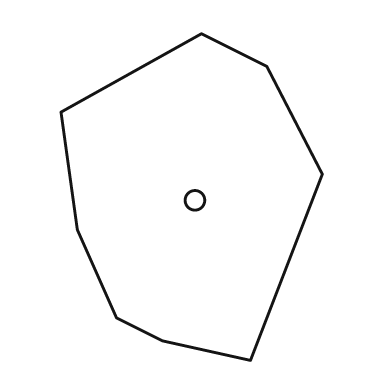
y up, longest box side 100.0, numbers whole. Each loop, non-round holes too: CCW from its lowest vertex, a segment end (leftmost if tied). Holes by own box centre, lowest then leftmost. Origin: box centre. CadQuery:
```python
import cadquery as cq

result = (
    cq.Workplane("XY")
    .moveTo(18.0, -50.0)
    .lineTo(40.0, 7.0)
    .lineTo(23.0, 40.0)
    .lineTo(3.0, 50.0)
    .lineTo(-40.0, 26.0)
    .lineTo(-35.0, -10.0)
    .lineTo(-23.0, -37.0)
    .lineTo(-9.0, -44.0)
    .close()
    .moveTo(1.0, -1.0)
    .circle(3.0)
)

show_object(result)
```